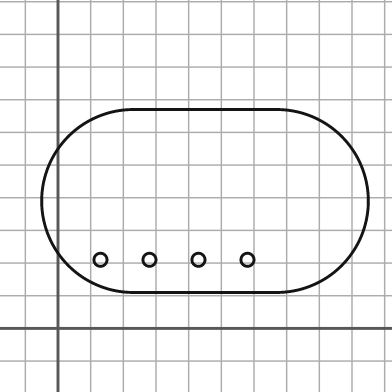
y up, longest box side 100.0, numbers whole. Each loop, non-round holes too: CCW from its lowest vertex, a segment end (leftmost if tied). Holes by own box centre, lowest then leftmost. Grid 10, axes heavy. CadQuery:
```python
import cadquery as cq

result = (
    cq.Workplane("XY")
    .moveTo(23.0, 11.0)
    .lineTo(67.0, 11.0)
    .threePointArc((95.0, 39.0), (67.0, 67.0))
    .lineTo(23.0, 67.0)
    .threePointArc((-5.0, 39.0), (23.0, 11.0))
    .close()
    .moveTo(13.0, 21.0)
    .circle(2.0)
    .moveTo(28.0, 21.0)
    .circle(2.0)
    .moveTo(43.0, 21.0)
    .circle(2.0)
    .moveTo(58.0, 21.0)
    .circle(2.0)
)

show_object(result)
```